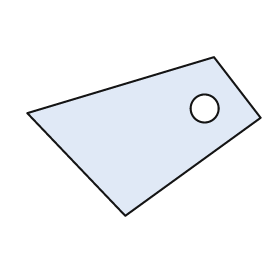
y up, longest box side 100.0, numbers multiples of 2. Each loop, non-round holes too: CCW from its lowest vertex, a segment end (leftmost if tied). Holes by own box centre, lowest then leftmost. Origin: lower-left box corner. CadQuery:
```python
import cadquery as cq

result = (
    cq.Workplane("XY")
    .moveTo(42.0, 0.0)
    .lineTo(100.0, 42.0)
    .lineTo(80.0, 68.0)
    .lineTo(0.0, 44.0)
    .close()
    .moveTo(76.0, 46.0)
    .circle(6.0)
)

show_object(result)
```